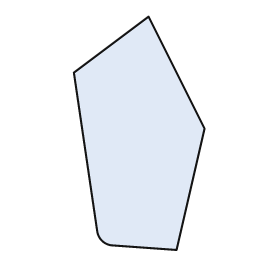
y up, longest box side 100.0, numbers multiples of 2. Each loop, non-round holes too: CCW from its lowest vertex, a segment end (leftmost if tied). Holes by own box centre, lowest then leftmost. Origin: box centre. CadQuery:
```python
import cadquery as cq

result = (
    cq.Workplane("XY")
    .moveTo(16.0, -50.0)
    .lineTo(28.0, 2.0)
    .lineTo(4.0, 50.0)
    .lineTo(-28.0, 26.0)
    .lineTo(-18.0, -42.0)
    .threePointArc((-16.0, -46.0), (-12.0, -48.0))
    .close()
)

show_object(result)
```